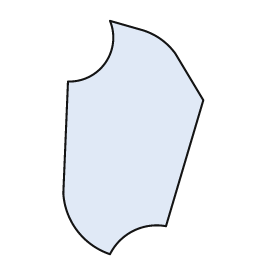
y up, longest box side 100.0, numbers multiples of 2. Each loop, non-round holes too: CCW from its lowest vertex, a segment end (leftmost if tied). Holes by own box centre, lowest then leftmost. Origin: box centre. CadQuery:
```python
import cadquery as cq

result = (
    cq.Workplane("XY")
    .moveTo(-10.0, -50.0)
    .threePointArc((0.0, -40.0), (14.0, -38.0))
    .lineTo(30.0, 16.0)
    .lineTo(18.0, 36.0)
    .threePointArc((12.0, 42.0), (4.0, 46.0))
    .lineTo(-10.0, 50.0)
    .threePointArc((-12.0, 32.0), (-28.0, 24.0))
    .lineTo(-30.0, -24.0)
    .threePointArc((-24.0, -40.0), (-10.0, -50.0))
    .close()
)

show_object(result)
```